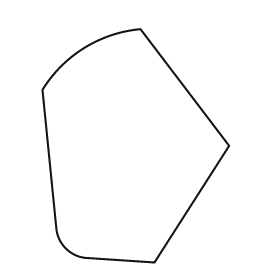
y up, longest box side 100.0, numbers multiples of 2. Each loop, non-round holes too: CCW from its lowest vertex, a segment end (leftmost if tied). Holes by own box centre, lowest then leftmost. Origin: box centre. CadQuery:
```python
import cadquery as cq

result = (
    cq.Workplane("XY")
    .moveTo(8.0, -50.0)
    .lineTo(40.0, 0.0)
    .lineTo(2.0, 50.0)
    .threePointArc((-22.0, 42.0), (-40.0, 24.0))
    .lineTo(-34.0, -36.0)
    .threePointArc((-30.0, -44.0), (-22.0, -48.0))
    .close()
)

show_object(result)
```